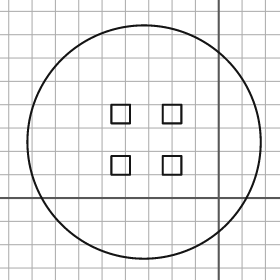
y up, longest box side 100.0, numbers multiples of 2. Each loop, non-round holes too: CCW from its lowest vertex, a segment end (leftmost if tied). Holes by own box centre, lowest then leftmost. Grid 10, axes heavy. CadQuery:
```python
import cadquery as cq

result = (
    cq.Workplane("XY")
    .moveTo(-32.0, 24.0)
    .circle(50.0)
    .moveTo(-46.0, 10.0)
    .lineTo(-38.0, 10.0)
    .lineTo(-38.0, 18.0)
    .lineTo(-46.0, 18.0)
    .close()
    .moveTo(-24.0, 10.0)
    .lineTo(-16.0, 10.0)
    .lineTo(-16.0, 18.0)
    .lineTo(-24.0, 18.0)
    .close()
    .moveTo(-46.0, 32.0)
    .lineTo(-38.0, 32.0)
    .lineTo(-38.0, 40.0)
    .lineTo(-46.0, 40.0)
    .close()
    .moveTo(-24.0, 32.0)
    .lineTo(-16.0, 32.0)
    .lineTo(-16.0, 40.0)
    .lineTo(-24.0, 40.0)
    .close()
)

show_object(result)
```